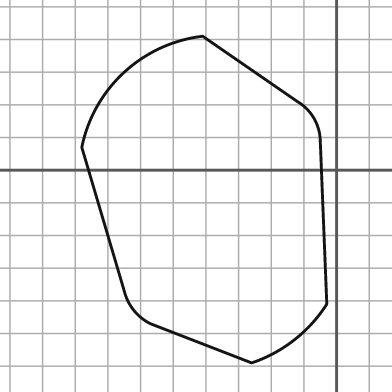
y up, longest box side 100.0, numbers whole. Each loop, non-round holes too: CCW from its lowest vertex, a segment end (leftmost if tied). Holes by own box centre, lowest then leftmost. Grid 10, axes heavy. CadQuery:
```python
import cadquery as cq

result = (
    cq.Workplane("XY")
    .moveTo(-26.0, -59.0)
    .threePointArc((-13.0, -52.0), (-3.0, -41.0))
    .lineTo(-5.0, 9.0)
    .threePointArc((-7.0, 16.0), (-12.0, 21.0))
    .lineTo(-41.0, 41.0)
    .threePointArc((-65.0, 30.0), (-78.0, 7.0))
    .lineTo(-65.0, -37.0)
    .threePointArc((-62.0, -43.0), (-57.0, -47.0))
    .close()
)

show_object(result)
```